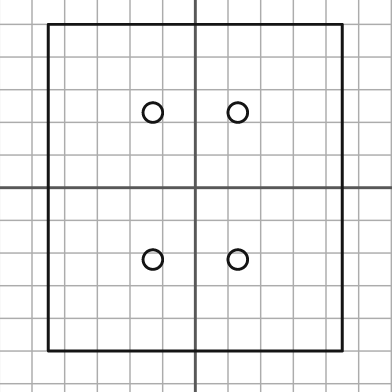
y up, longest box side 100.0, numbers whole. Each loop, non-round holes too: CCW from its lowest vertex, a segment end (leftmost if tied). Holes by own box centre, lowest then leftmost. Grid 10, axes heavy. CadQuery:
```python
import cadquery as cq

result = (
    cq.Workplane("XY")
    .moveTo(-45.0, -50.0)
    .lineTo(45.0, -50.0)
    .lineTo(45.0, 50.0)
    .lineTo(-45.0, 50.0)
    .close()
    .moveTo(-13.0, -22.0)
    .circle(3.0)
    .moveTo(13.0, -22.0)
    .circle(3.0)
    .moveTo(-13.0, 23.0)
    .circle(3.0)
    .moveTo(13.0, 23.0)
    .circle(3.0)
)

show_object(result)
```